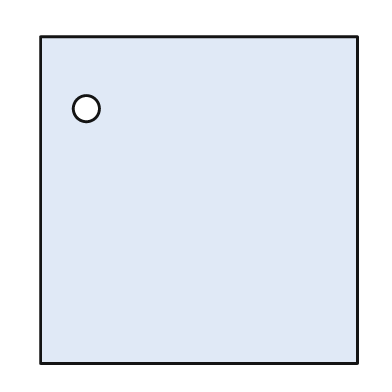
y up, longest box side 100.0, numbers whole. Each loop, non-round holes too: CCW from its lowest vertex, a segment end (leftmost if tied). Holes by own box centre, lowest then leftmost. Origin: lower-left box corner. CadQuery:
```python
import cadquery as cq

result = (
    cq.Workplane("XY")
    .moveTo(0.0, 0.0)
    .lineTo(97.0, 0.0)
    .lineTo(97.0, 100.0)
    .lineTo(0.0, 100.0)
    .close()
    .moveTo(14.0, 78.0)
    .circle(4.0)
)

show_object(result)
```